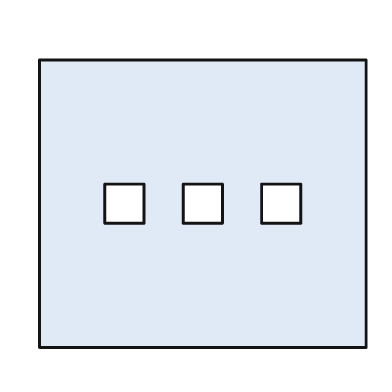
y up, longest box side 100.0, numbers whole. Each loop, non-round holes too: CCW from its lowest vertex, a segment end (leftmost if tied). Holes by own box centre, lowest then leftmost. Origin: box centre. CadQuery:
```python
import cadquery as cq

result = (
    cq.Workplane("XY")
    .moveTo(-50.0, -44.0)
    .lineTo(50.0, -44.0)
    .lineTo(50.0, 44.0)
    .lineTo(-50.0, 44.0)
    .close()
    .moveTo(-30.0, -6.0)
    .lineTo(-18.0, -6.0)
    .lineTo(-18.0, 6.0)
    .lineTo(-30.0, 6.0)
    .close()
    .moveTo(-6.0, -6.0)
    .lineTo(6.0, -6.0)
    .lineTo(6.0, 6.0)
    .lineTo(-6.0, 6.0)
    .close()
    .moveTo(18.0, -6.0)
    .lineTo(30.0, -6.0)
    .lineTo(30.0, 6.0)
    .lineTo(18.0, 6.0)
    .close()
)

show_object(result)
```